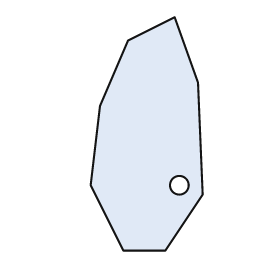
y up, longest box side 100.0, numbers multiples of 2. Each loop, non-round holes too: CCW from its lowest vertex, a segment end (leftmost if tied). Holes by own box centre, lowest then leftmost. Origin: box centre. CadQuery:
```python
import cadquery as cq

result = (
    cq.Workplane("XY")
    .moveTo(-10.0, -50.0)
    .lineTo(8.0, -50.0)
    .lineTo(24.0, -26.0)
    .lineTo(22.0, 22.0)
    .lineTo(12.0, 50.0)
    .lineTo(-8.0, 40.0)
    .lineTo(-20.0, 12.0)
    .lineTo(-24.0, -22.0)
    .close()
    .moveTo(14.0, -22.0)
    .circle(4.0)
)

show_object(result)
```